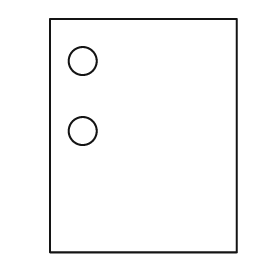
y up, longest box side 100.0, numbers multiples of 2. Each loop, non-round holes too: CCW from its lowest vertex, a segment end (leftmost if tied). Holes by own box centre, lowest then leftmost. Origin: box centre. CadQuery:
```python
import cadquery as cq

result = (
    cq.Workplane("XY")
    .moveTo(-40.0, -50.0)
    .lineTo(40.0, -50.0)
    .lineTo(40.0, 50.0)
    .lineTo(-40.0, 50.0)
    .close()
    .moveTo(-26.0, 2.0)
    .circle(6.0)
    .moveTo(-26.0, 32.0)
    .circle(6.0)
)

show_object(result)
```